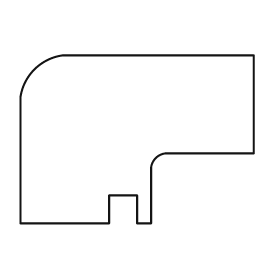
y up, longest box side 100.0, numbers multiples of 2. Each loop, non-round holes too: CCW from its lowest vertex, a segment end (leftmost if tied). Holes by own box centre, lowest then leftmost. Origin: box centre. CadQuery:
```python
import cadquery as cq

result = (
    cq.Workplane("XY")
    .moveTo(-50.0, -36.0)
    .lineTo(-12.0, -36.0)
    .lineTo(-12.0, -24.0)
    .lineTo(0.0, -24.0)
    .lineTo(0.0, -36.0)
    .lineTo(6.0, -36.0)
    .lineTo(6.0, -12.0)
    .threePointArc((8.0, -8.0), (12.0, -6.0))
    .lineTo(50.0, -6.0)
    .lineTo(50.0, 36.0)
    .lineTo(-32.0, 36.0)
    .threePointArc((-44.0, 30.0), (-50.0, 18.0))
    .close()
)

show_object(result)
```